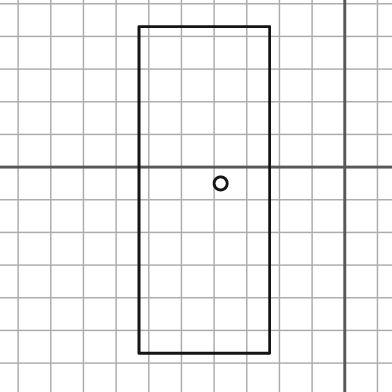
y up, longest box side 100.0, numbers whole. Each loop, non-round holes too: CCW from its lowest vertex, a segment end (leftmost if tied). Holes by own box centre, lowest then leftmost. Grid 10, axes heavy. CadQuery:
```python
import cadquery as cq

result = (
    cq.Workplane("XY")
    .moveTo(-63.0, -57.0)
    .lineTo(-23.0, -57.0)
    .lineTo(-23.0, 43.0)
    .lineTo(-63.0, 43.0)
    .close()
    .moveTo(-38.0, -5.0)
    .circle(2.0)
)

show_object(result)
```